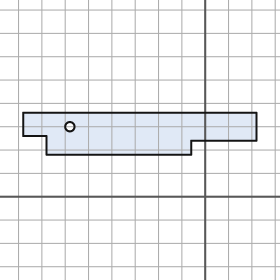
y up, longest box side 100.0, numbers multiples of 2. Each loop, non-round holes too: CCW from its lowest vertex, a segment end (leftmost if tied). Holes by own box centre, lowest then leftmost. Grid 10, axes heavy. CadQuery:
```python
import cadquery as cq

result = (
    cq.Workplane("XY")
    .moveTo(-68.0, 18.0)
    .lineTo(-6.0, 18.0)
    .lineTo(-6.0, 24.0)
    .lineTo(22.0, 24.0)
    .lineTo(22.0, 36.0)
    .lineTo(-78.0, 36.0)
    .lineTo(-78.0, 26.0)
    .lineTo(-68.0, 26.0)
    .close()
    .moveTo(-58.0, 30.0)
    .circle(2.0)
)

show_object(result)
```